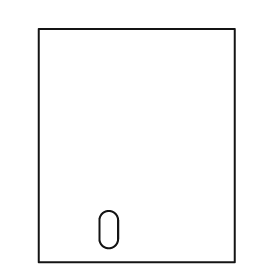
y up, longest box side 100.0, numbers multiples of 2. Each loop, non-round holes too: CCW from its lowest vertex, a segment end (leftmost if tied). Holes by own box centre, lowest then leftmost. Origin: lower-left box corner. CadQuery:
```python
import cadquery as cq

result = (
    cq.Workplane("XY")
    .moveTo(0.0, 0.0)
    .lineTo(84.0, 0.0)
    .lineTo(84.0, 100.0)
    .lineTo(0.0, 100.0)
    .close()
    .moveTo(26.0, 10.0)
    .threePointArc((30.0, 6.0), (34.0, 10.0))
    .lineTo(34.0, 18.0)
    .threePointArc((30.0, 22.0), (26.0, 18.0))
    .close()
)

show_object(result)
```